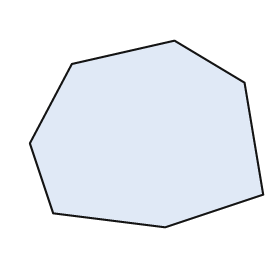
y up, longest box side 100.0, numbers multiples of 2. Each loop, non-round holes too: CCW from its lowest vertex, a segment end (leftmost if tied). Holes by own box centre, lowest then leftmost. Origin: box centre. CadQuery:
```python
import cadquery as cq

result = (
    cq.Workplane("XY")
    .moveTo(8.0, -40.0)
    .lineTo(50.0, -26.0)
    .lineTo(42.0, 22.0)
    .lineTo(12.0, 40.0)
    .lineTo(-32.0, 30.0)
    .lineTo(-50.0, -4.0)
    .lineTo(-40.0, -34.0)
    .close()
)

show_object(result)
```